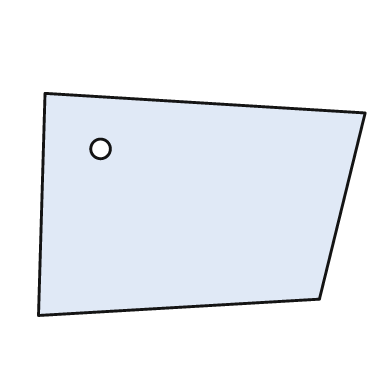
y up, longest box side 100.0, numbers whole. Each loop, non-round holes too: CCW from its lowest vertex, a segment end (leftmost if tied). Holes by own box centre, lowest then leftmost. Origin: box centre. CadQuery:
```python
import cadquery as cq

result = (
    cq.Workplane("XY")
    .moveTo(-50.0, -34.0)
    .lineTo(36.0, -29.0)
    .lineTo(50.0, 28.0)
    .lineTo(-48.0, 34.0)
    .close()
    .moveTo(-31.0, 17.0)
    .circle(3.0)
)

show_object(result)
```